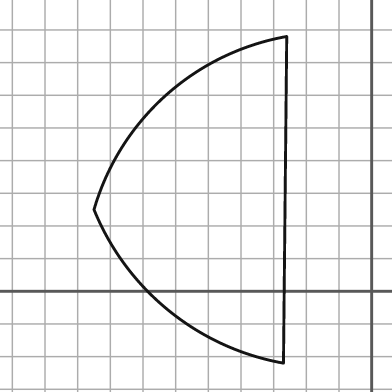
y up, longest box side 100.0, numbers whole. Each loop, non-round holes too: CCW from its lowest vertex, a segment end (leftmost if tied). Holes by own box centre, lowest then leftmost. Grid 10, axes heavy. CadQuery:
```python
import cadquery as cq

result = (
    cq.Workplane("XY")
    .moveTo(-27.0, -22.0)
    .lineTo(-26.0, 78.0)
    .threePointArc((-63.0, 60.0), (-85.0, 25.0))
    .threePointArc((-62.0, -6.0), (-27.0, -22.0))
    .close()
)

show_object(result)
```